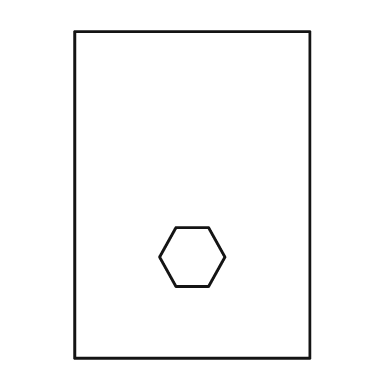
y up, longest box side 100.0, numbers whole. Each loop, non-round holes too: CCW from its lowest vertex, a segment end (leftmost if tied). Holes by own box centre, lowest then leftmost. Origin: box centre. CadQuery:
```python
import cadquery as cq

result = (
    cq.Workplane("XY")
    .moveTo(-36.0, -50.0)
    .lineTo(36.0, -50.0)
    .lineTo(36.0, 50.0)
    .lineTo(-36.0, 50.0)
    .close()
    .moveTo(-5.0, -28.0)
    .lineTo(5.0, -28.0)
    .lineTo(10.0, -19.0)
    .lineTo(5.0, -10.0)
    .lineTo(-5.0, -10.0)
    .lineTo(-10.0, -19.0)
    .close()
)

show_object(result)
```